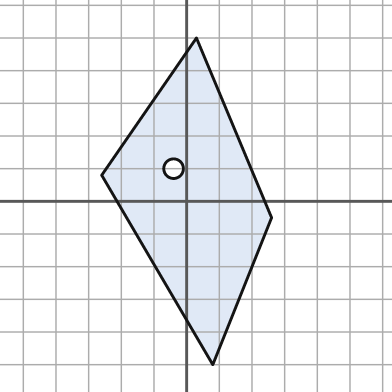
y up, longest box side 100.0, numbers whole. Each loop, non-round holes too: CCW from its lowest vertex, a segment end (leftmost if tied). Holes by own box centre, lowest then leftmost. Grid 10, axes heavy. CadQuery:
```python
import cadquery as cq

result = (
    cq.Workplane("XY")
    .moveTo(8.0, -50.0)
    .lineTo(26.0, -5.0)
    .lineTo(3.0, 50.0)
    .lineTo(-26.0, 8.0)
    .close()
    .moveTo(-4.0, 10.0)
    .circle(3.0)
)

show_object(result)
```